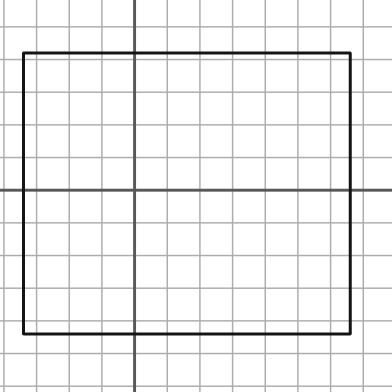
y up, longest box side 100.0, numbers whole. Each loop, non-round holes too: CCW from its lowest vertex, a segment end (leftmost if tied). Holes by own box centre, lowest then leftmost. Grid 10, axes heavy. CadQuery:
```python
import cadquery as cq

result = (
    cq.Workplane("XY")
    .moveTo(-34.0, -44.0)
    .lineTo(66.0, -44.0)
    .lineTo(66.0, 42.0)
    .lineTo(-34.0, 42.0)
    .close()
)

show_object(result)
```